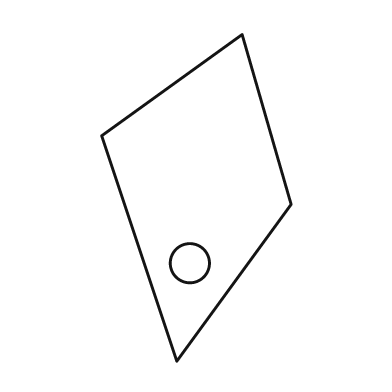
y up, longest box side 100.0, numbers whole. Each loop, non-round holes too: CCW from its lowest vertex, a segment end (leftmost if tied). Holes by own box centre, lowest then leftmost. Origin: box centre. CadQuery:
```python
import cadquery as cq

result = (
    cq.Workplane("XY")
    .moveTo(-6.0, -50.0)
    .lineTo(29.0, -2.0)
    .lineTo(14.0, 50.0)
    .lineTo(-29.0, 19.0)
    .close()
    .moveTo(-2.0, -20.0)
    .circle(6.0)
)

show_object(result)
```